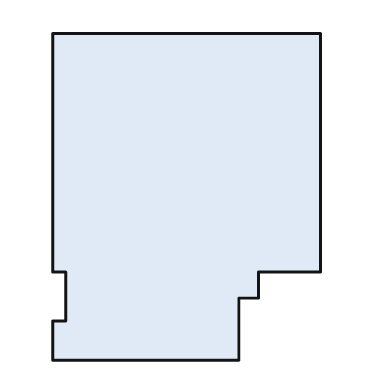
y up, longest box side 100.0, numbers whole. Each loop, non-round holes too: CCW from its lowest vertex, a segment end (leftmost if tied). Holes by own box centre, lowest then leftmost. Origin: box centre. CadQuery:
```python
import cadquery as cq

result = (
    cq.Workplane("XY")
    .moveTo(-41.0, -50.0)
    .lineTo(16.0, -50.0)
    .lineTo(16.0, -31.0)
    .lineTo(22.0, -31.0)
    .lineTo(22.0, -23.0)
    .lineTo(41.0, -23.0)
    .lineTo(41.0, 50.0)
    .lineTo(-41.0, 50.0)
    .lineTo(-41.0, -23.0)
    .lineTo(-37.0, -23.0)
    .lineTo(-37.0, -38.0)
    .lineTo(-41.0, -38.0)
    .close()
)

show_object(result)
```